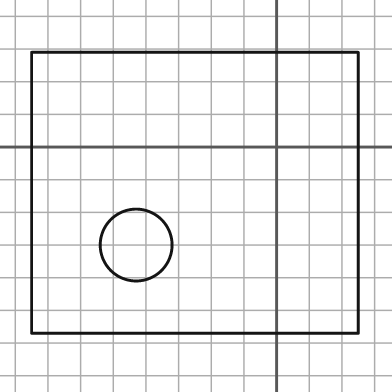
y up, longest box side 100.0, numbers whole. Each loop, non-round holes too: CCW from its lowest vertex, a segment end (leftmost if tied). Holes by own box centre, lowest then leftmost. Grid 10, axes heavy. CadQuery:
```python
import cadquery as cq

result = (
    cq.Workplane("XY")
    .moveTo(-75.0, -57.0)
    .lineTo(25.0, -57.0)
    .lineTo(25.0, 29.0)
    .lineTo(-75.0, 29.0)
    .close()
    .moveTo(-43.0, -30.0)
    .circle(11.0)
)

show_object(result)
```